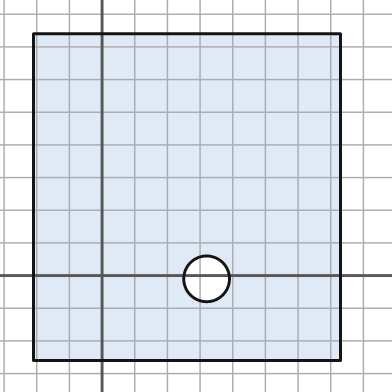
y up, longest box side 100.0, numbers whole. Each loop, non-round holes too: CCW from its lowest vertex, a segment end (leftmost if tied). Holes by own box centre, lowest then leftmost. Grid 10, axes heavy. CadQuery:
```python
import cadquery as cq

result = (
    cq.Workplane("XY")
    .moveTo(-21.0, -26.0)
    .lineTo(73.0, -26.0)
    .lineTo(73.0, 74.0)
    .lineTo(-21.0, 74.0)
    .close()
    .moveTo(32.0, -1.0)
    .circle(7.0)
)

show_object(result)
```